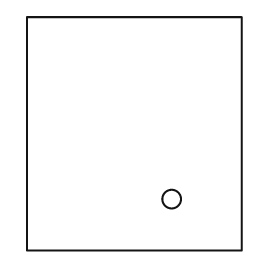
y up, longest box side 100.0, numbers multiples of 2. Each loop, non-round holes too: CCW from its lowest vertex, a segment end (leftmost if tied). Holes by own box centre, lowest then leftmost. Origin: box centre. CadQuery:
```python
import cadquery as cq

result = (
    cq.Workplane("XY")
    .moveTo(-46.0, -50.0)
    .lineTo(46.0, -50.0)
    .lineTo(46.0, 50.0)
    .lineTo(-46.0, 50.0)
    .close()
    .moveTo(16.0, -28.0)
    .circle(4.0)
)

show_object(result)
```